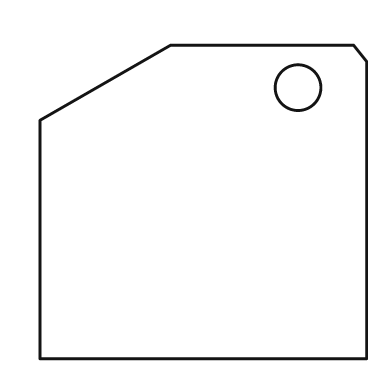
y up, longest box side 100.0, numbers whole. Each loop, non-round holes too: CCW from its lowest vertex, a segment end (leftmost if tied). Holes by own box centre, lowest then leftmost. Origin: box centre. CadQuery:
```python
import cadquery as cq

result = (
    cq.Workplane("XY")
    .moveTo(-50.0, -48.0)
    .lineTo(50.0, -48.0)
    .lineTo(50.0, 43.0)
    .lineTo(46.0, 48.0)
    .lineTo(-10.0, 48.0)
    .lineTo(-50.0, 25.0)
    .close()
    .moveTo(29.0, 35.0)
    .circle(7.0)
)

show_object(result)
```